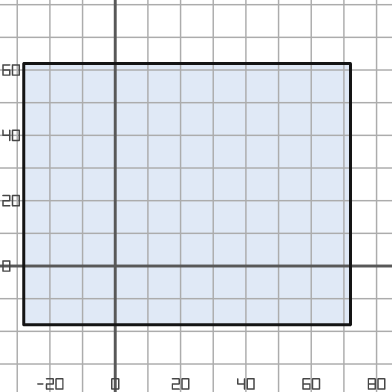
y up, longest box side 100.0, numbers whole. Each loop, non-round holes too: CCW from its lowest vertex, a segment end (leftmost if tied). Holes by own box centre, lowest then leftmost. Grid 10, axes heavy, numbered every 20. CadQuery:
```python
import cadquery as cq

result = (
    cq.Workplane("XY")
    .moveTo(-28.0, -18.0)
    .lineTo(72.0, -18.0)
    .lineTo(72.0, 62.0)
    .lineTo(-28.0, 62.0)
    .close()
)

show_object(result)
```